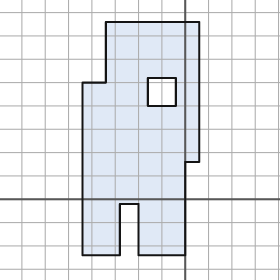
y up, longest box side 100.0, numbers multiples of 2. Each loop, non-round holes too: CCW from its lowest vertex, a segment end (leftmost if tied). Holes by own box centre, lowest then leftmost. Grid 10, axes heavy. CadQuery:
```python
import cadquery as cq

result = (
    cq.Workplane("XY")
    .moveTo(-44.0, -24.0)
    .lineTo(-28.0, -24.0)
    .lineTo(-28.0, -2.0)
    .lineTo(-20.0, -2.0)
    .lineTo(-20.0, -24.0)
    .lineTo(0.0, -24.0)
    .lineTo(0.0, 16.0)
    .lineTo(6.0, 16.0)
    .lineTo(6.0, 76.0)
    .lineTo(-34.0, 76.0)
    .lineTo(-34.0, 50.0)
    .lineTo(-44.0, 50.0)
    .close()
    .moveTo(-16.0, 40.0)
    .lineTo(-4.0, 40.0)
    .lineTo(-4.0, 52.0)
    .lineTo(-16.0, 52.0)
    .close()
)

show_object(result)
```